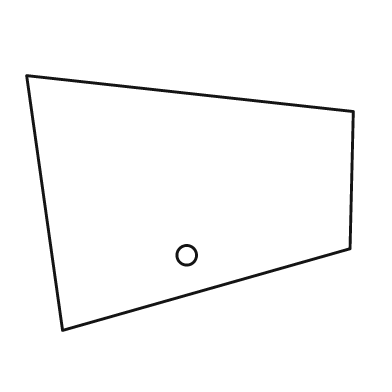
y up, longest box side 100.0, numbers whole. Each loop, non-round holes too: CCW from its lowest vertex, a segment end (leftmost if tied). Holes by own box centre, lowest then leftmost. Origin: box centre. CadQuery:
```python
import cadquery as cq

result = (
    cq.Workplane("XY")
    .moveTo(-39.0, -39.0)
    .lineTo(49.0, -14.0)
    .lineTo(50.0, 28.0)
    .lineTo(-50.0, 39.0)
    .close()
    .moveTo(-1.0, -16.0)
    .circle(3.0)
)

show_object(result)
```